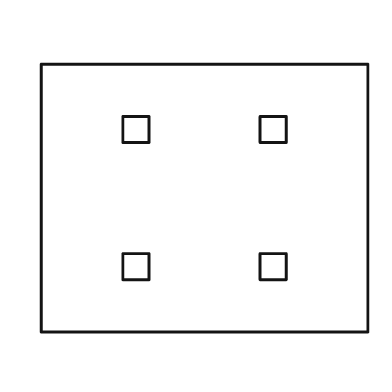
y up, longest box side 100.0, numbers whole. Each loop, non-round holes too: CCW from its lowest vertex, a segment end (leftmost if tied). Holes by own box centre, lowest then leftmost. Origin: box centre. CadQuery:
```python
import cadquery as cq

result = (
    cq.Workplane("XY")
    .moveTo(-50.0, -41.0)
    .lineTo(50.0, -41.0)
    .lineTo(50.0, 41.0)
    .lineTo(-50.0, 41.0)
    .close()
    .moveTo(-25.0, -25.0)
    .lineTo(-17.0, -25.0)
    .lineTo(-17.0, -17.0)
    .lineTo(-25.0, -17.0)
    .close()
    .moveTo(17.0, -25.0)
    .lineTo(25.0, -25.0)
    .lineTo(25.0, -17.0)
    .lineTo(17.0, -17.0)
    .close()
    .moveTo(-25.0, 17.0)
    .lineTo(-17.0, 17.0)
    .lineTo(-17.0, 25.0)
    .lineTo(-25.0, 25.0)
    .close()
    .moveTo(17.0, 17.0)
    .lineTo(25.0, 17.0)
    .lineTo(25.0, 25.0)
    .lineTo(17.0, 25.0)
    .close()
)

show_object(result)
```